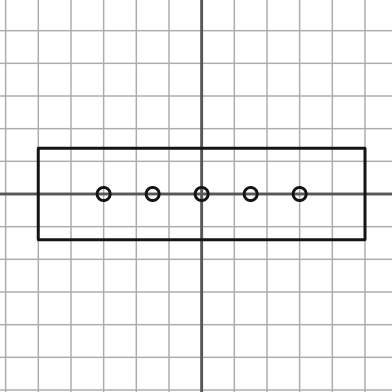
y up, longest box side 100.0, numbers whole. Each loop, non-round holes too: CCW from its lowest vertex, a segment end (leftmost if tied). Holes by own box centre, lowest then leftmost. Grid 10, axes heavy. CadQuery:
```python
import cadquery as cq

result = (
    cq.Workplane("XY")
    .moveTo(-50.0, -14.0)
    .lineTo(50.0, -14.0)
    .lineTo(50.0, 14.0)
    .lineTo(-50.0, 14.0)
    .close()
    .moveTo(-30.0, 0.0)
    .circle(2.0)
    .moveTo(-15.0, 0.0)
    .circle(2.0)
    .moveTo(0.0, 0.0)
    .circle(2.0)
    .moveTo(15.0, 0.0)
    .circle(2.0)
    .moveTo(30.0, 0.0)
    .circle(2.0)
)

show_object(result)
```